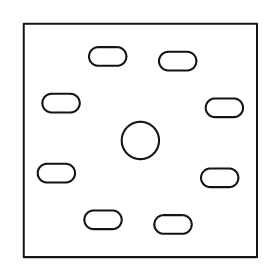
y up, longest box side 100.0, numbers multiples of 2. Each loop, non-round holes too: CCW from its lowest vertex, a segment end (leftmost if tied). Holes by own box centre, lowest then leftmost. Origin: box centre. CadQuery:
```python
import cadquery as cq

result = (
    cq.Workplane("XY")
    .moveTo(-50.0, -50.0)
    .lineTo(50.0, -50.0)
    .lineTo(50.0, 50.0)
    .lineTo(-50.0, 50.0)
    .close()
    .moveTo(10.0, -40.0)
    .lineTo(18.0, -40.0)
    .threePointArc((22.0, -36.0), (18.0, -32.0))
    .lineTo(10.0, -32.0)
    .threePointArc((6.0, -36.0), (10.0, -40.0))
    .close()
    .moveTo(-20.0, -38.0)
    .lineTo(-12.0, -38.0)
    .threePointArc((-8.0, -34.0), (-12.0, -30.0))
    .lineTo(-20.0, -30.0)
    .threePointArc((-24.0, -34.0), (-20.0, -38.0))
    .close()
    .moveTo(30.0, -20.0)
    .lineTo(38.0, -20.0)
    .threePointArc((42.0, -16.0), (38.0, -12.0))
    .lineTo(30.0, -12.0)
    .threePointArc((26.0, -16.0), (30.0, -20.0))
    .close()
    .moveTo(-40.0, -18.0)
    .lineTo(-32.0, -18.0)
    .threePointArc((-28.0, -14.0), (-32.0, -10.0))
    .lineTo(-40.0, -10.0)
    .threePointArc((-44.0, -14.0), (-40.0, -18.0))
    .close()
    .moveTo(0.0, 0.0)
    .circle(8.0)
    .moveTo(32.0, 10.0)
    .lineTo(40.0, 10.0)
    .threePointArc((44.0, 14.0), (40.0, 18.0))
    .lineTo(32.0, 18.0)
    .threePointArc((28.0, 14.0), (32.0, 10.0))
    .close()
    .moveTo(-38.0, 12.0)
    .lineTo(-30.0, 12.0)
    .threePointArc((-26.0, 16.0), (-30.0, 20.0))
    .lineTo(-38.0, 20.0)
    .threePointArc((-42.0, 16.0), (-38.0, 12.0))
    .close()
    .moveTo(12.0, 30.0)
    .lineTo(20.0, 30.0)
    .threePointArc((24.0, 34.0), (20.0, 38.0))
    .lineTo(12.0, 38.0)
    .threePointArc((8.0, 34.0), (12.0, 30.0))
    .close()
    .moveTo(-18.0, 32.0)
    .lineTo(-10.0, 32.0)
    .threePointArc((-6.0, 36.0), (-10.0, 40.0))
    .lineTo(-18.0, 40.0)
    .threePointArc((-22.0, 36.0), (-18.0, 32.0))
    .close()
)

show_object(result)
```